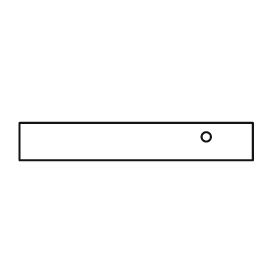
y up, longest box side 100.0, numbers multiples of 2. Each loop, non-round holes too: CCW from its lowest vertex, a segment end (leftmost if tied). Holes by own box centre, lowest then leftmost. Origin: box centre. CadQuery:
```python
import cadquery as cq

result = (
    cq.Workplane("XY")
    .moveTo(-50.0, -8.0)
    .lineTo(50.0, -8.0)
    .lineTo(50.0, 8.0)
    .lineTo(-50.0, 8.0)
    .close()
    .moveTo(30.0, 2.0)
    .circle(2.0)
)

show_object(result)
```